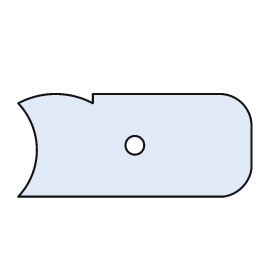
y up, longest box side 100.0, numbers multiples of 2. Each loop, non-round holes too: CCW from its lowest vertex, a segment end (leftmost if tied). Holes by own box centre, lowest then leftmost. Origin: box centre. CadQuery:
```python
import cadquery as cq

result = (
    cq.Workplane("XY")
    .moveTo(-50.0, -22.0)
    .lineTo(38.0, -22.0)
    .threePointArc((46.0, -18.0), (50.0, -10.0))
    .lineTo(50.0, 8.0)
    .threePointArc((46.0, 18.0), (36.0, 22.0))
    .lineTo(-18.0, 22.0)
    .lineTo(-18.0, 18.0)
    .threePointArc((-34.0, 22.0), (-50.0, 18.0))
    .threePointArc((-42.0, -2.0), (-50.0, -22.0))
    .close()
    .moveTo(0.0, 0.0)
    .circle(4.0)
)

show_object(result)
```